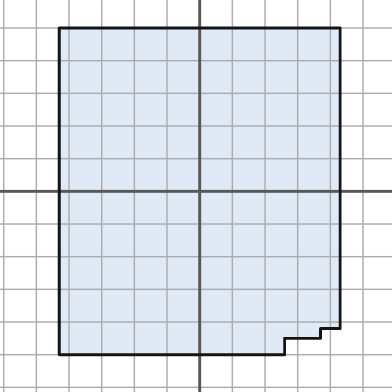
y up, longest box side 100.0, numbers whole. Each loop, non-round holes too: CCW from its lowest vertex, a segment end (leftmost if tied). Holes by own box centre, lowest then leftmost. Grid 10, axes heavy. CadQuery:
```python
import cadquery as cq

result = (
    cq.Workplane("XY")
    .moveTo(-43.0, -50.0)
    .lineTo(26.0, -50.0)
    .lineTo(26.0, -45.0)
    .lineTo(37.0, -45.0)
    .lineTo(37.0, -42.0)
    .lineTo(43.0, -42.0)
    .lineTo(43.0, 50.0)
    .lineTo(-43.0, 50.0)
    .close()
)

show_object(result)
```